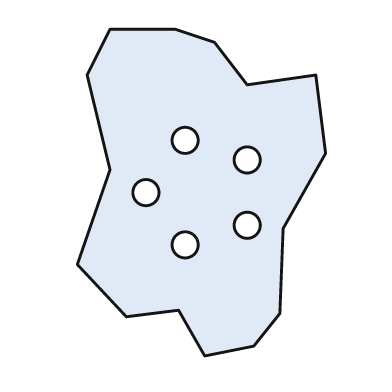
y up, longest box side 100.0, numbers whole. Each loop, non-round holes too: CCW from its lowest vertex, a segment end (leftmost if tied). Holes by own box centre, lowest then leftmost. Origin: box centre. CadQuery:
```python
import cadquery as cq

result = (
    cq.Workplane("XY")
    .moveTo(1.0, -50.0)
    .lineTo(16.0, -47.0)
    .lineTo(24.0, -37.0)
    .lineTo(25.0, -11.0)
    .lineTo(38.0, 12.0)
    .lineTo(35.0, 36.0)
    .lineTo(14.0, 33.0)
    .lineTo(4.0, 46.0)
    .lineTo(-8.0, 50.0)
    .lineTo(-28.0, 50.0)
    .lineTo(-35.0, 36.0)
    .lineTo(-28.0, 7.0)
    .lineTo(-38.0, -22.0)
    .lineTo(-23.0, -38.0)
    .lineTo(-7.0, -36.0)
    .close()
    .moveTo(-5.0, -16.0)
    .circle(4.0)
    .moveTo(14.0, -10.0)
    .circle(4.0)
    .moveTo(-17.0, 0.0)
    .circle(4.0)
    .moveTo(14.0, 10.0)
    .circle(4.0)
    .moveTo(-5.0, 16.0)
    .circle(4.0)
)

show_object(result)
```